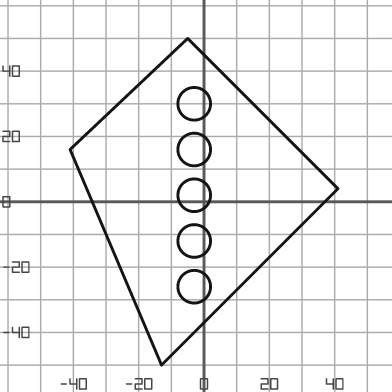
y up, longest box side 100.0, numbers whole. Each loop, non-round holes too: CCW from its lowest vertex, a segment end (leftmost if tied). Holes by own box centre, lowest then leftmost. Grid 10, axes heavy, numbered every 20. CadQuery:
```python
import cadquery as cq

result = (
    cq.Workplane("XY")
    .moveTo(-13.0, -50.0)
    .lineTo(41.0, 4.0)
    .lineTo(-5.0, 50.0)
    .lineTo(-41.0, 16.0)
    .close()
    .moveTo(-3.0, -26.0)
    .circle(5.0)
    .moveTo(-3.0, -12.0)
    .circle(5.0)
    .moveTo(-3.0, 2.0)
    .circle(5.0)
    .moveTo(-3.0, 16.0)
    .circle(5.0)
    .moveTo(-3.0, 30.0)
    .circle(5.0)
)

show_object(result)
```